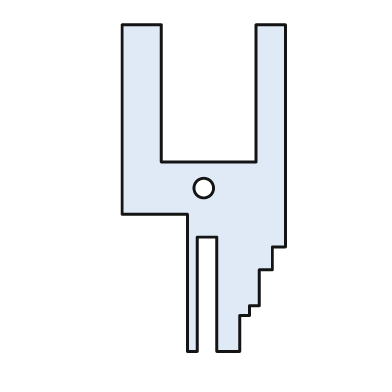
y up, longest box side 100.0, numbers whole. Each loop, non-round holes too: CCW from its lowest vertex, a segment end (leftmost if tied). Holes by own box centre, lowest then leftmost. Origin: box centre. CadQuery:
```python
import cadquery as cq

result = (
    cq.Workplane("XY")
    .moveTo(-5.0, -50.0)
    .lineTo(-2.0, -50.0)
    .lineTo(-2.0, -15.0)
    .lineTo(4.0, -15.0)
    .lineTo(4.0, -50.0)
    .lineTo(11.0, -50.0)
    .lineTo(11.0, -39.0)
    .lineTo(14.0, -39.0)
    .lineTo(14.0, -36.0)
    .lineTo(17.0, -36.0)
    .lineTo(17.0, -25.0)
    .lineTo(21.0, -25.0)
    .lineTo(21.0, -18.0)
    .lineTo(25.0, -18.0)
    .lineTo(25.0, 50.0)
    .lineTo(16.0, 50.0)
    .lineTo(16.0, 8.0)
    .lineTo(-13.0, 8.0)
    .lineTo(-13.0, 50.0)
    .lineTo(-25.0, 50.0)
    .lineTo(-25.0, -8.0)
    .lineTo(-5.0, -8.0)
    .close()
    .moveTo(0.0, 0.0)
    .circle(3.0)
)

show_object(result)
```